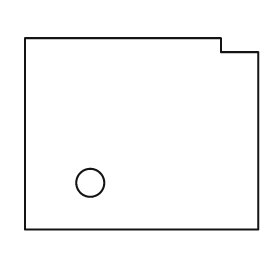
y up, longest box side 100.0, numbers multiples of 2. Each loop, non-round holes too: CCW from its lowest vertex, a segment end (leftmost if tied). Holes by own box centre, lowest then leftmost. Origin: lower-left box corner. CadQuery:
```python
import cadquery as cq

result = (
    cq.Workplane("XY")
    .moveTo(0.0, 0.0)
    .lineTo(100.0, 0.0)
    .lineTo(100.0, 76.0)
    .lineTo(84.0, 76.0)
    .lineTo(84.0, 82.0)
    .lineTo(0.0, 82.0)
    .close()
    .moveTo(28.0, 20.0)
    .circle(6.0)
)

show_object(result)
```